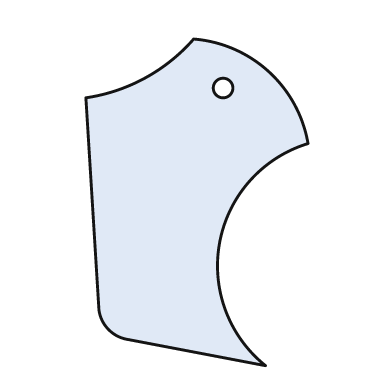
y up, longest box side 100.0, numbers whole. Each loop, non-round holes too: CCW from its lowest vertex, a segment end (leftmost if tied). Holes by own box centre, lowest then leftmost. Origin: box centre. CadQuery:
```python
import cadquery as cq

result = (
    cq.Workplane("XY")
    .moveTo(21.0, -50.0)
    .threePointArc((7.0, -12.0), (34.0, 18.0))
    .threePointArc((22.0, 40.0), (-1.0, 50.0))
    .threePointArc((-16.0, 38.0), (-34.0, 32.0))
    .lineTo(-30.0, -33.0)
    .threePointArc((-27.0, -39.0), (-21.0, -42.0))
    .close()
    .moveTo(8.0, 35.0)
    .circle(3.0)
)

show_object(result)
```